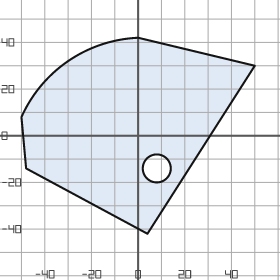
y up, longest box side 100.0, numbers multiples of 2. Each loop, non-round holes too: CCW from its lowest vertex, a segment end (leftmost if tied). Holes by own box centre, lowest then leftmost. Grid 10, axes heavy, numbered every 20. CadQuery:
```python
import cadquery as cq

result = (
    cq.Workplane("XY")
    .moveTo(4.0, -42.0)
    .lineTo(50.0, 30.0)
    .lineTo(0.0, 42.0)
    .threePointArc((-30.0, 32.0), (-50.0, 8.0))
    .lineTo(-48.0, -14.0)
    .close()
    .moveTo(8.0, -14.0)
    .circle(6.0)
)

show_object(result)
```